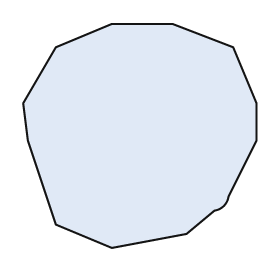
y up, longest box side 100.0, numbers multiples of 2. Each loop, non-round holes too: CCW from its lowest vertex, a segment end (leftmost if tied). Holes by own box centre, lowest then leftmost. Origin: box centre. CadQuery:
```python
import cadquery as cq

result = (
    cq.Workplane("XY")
    .moveTo(-12.0, -48.0)
    .lineTo(20.0, -42.0)
    .lineTo(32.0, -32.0)
    .threePointArc((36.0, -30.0), (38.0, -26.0))
    .lineTo(50.0, -2.0)
    .lineTo(50.0, 14.0)
    .lineTo(40.0, 38.0)
    .lineTo(14.0, 48.0)
    .lineTo(-12.0, 48.0)
    .lineTo(-36.0, 38.0)
    .lineTo(-50.0, 14.0)
    .lineTo(-48.0, -2.0)
    .lineTo(-36.0, -38.0)
    .close()
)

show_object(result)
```